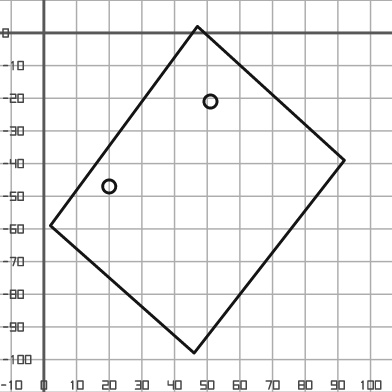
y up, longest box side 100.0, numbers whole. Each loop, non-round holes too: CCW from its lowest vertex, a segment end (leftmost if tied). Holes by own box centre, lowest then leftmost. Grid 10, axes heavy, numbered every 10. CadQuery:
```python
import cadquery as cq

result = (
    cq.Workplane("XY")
    .moveTo(46.0, -98.0)
    .lineTo(92.0, -39.0)
    .lineTo(47.0, 2.0)
    .lineTo(2.0, -59.0)
    .close()
    .moveTo(20.0, -47.0)
    .circle(2.0)
    .moveTo(51.0, -21.0)
    .circle(2.0)
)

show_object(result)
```